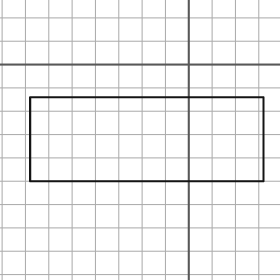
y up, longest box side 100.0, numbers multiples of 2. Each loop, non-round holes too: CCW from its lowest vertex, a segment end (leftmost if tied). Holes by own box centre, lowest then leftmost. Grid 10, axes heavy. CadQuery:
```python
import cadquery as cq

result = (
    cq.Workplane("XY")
    .moveTo(-68.0, -50.0)
    .lineTo(32.0, -50.0)
    .lineTo(32.0, -14.0)
    .lineTo(-68.0, -14.0)
    .close()
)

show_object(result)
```